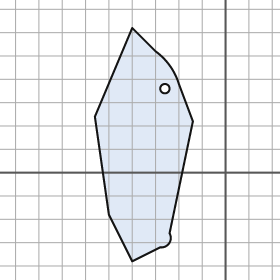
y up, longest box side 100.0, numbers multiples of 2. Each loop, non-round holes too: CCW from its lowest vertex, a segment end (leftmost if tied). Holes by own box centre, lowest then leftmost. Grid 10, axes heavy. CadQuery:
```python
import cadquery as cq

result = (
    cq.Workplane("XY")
    .moveTo(-40.0, -38.0)
    .lineTo(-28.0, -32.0)
    .threePointArc((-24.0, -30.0), (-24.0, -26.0))
    .lineTo(-14.0, 22.0)
    .lineTo(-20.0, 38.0)
    .threePointArc((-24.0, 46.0), (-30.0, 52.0))
    .lineTo(-40.0, 62.0)
    .lineTo(-56.0, 24.0)
    .lineTo(-50.0, -18.0)
    .close()
    .moveTo(-26.0, 36.0)
    .circle(2.0)
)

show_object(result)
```